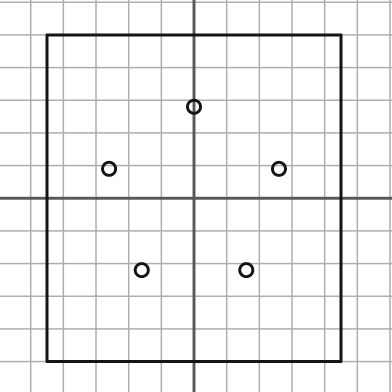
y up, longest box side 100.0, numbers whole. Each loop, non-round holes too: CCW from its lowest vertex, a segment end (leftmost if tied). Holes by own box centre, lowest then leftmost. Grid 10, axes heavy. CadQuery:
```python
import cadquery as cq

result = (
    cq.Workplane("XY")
    .moveTo(-45.0, -50.0)
    .lineTo(45.0, -50.0)
    .lineTo(45.0, 50.0)
    .lineTo(-45.0, 50.0)
    .close()
    .moveTo(-16.0, -22.0)
    .circle(2.0)
    .moveTo(16.0, -22.0)
    .circle(2.0)
    .moveTo(-26.0, 9.0)
    .circle(2.0)
    .moveTo(26.0, 9.0)
    .circle(2.0)
    .moveTo(0.0, 28.0)
    .circle(2.0)
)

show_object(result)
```